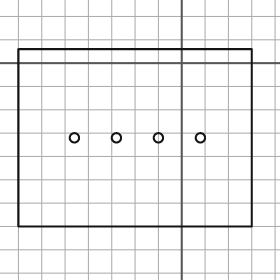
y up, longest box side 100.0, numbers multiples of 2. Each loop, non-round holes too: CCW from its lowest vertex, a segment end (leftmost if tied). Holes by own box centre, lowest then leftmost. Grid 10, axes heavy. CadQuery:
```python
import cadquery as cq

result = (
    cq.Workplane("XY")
    .moveTo(-70.0, -70.0)
    .lineTo(30.0, -70.0)
    .lineTo(30.0, 6.0)
    .lineTo(-70.0, 6.0)
    .close()
    .moveTo(-46.0, -32.0)
    .circle(2.0)
    .moveTo(-28.0, -32.0)
    .circle(2.0)
    .moveTo(-10.0, -32.0)
    .circle(2.0)
    .moveTo(8.0, -32.0)
    .circle(2.0)
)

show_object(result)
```